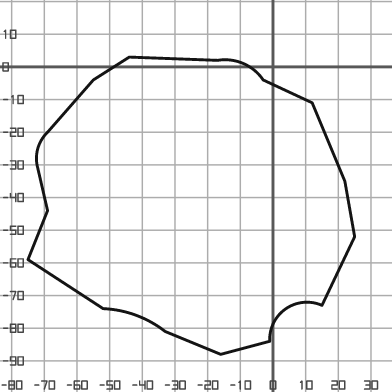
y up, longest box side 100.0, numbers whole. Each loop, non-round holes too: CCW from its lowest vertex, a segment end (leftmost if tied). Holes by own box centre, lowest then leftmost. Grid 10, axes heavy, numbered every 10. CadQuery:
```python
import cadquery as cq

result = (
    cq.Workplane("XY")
    .moveTo(-16.0, -88.0)
    .lineTo(-1.0, -84.0)
    .threePointArc((4.0, -74.0), (15.0, -73.0))
    .lineTo(25.0, -52.0)
    .lineTo(22.0, -35.0)
    .lineTo(12.0, -11.0)
    .lineTo(-3.0, -4.0)
    .threePointArc((-9.0, 1.0), (-17.0, 2.0))
    .lineTo(-44.0, 3.0)
    .lineTo(-55.0, -4.0)
    .lineTo(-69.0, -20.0)
    .threePointArc((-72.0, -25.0), (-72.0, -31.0))
    .lineTo(-69.0, -44.0)
    .lineTo(-75.0, -59.0)
    .lineTo(-52.0, -74.0)
    .threePointArc((-42.0, -76.0), (-33.0, -81.0))
    .close()
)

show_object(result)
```